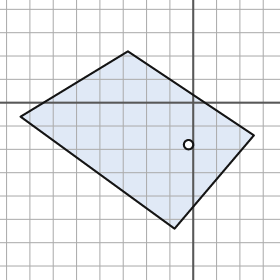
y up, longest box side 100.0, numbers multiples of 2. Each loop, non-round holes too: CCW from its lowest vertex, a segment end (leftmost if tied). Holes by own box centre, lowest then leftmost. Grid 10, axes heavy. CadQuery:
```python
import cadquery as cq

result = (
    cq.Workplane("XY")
    .moveTo(-8.0, -54.0)
    .lineTo(26.0, -14.0)
    .lineTo(-28.0, 22.0)
    .lineTo(-74.0, -6.0)
    .close()
    .moveTo(-2.0, -18.0)
    .circle(2.0)
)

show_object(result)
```